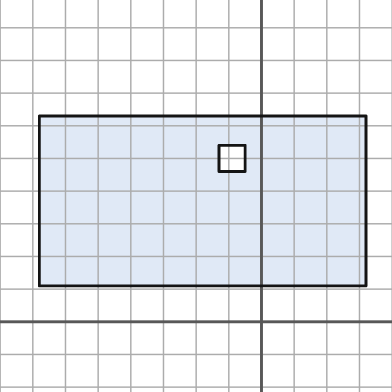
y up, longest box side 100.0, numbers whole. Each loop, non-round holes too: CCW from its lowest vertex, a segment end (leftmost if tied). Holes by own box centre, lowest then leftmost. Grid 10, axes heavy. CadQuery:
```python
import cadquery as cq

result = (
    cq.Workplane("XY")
    .moveTo(-68.0, 11.0)
    .lineTo(32.0, 11.0)
    .lineTo(32.0, 63.0)
    .lineTo(-68.0, 63.0)
    .close()
    .moveTo(-13.0, 46.0)
    .lineTo(-5.0, 46.0)
    .lineTo(-5.0, 54.0)
    .lineTo(-13.0, 54.0)
    .close()
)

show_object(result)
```